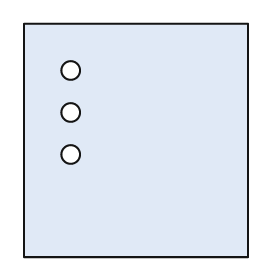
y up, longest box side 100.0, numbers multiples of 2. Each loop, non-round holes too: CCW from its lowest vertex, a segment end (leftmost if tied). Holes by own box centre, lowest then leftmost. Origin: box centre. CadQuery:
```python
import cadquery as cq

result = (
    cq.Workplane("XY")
    .moveTo(-48.0, -50.0)
    .lineTo(48.0, -50.0)
    .lineTo(48.0, 50.0)
    .lineTo(-48.0, 50.0)
    .close()
    .moveTo(-28.0, -6.0)
    .circle(4.0)
    .moveTo(-28.0, 12.0)
    .circle(4.0)
    .moveTo(-28.0, 30.0)
    .circle(4.0)
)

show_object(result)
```